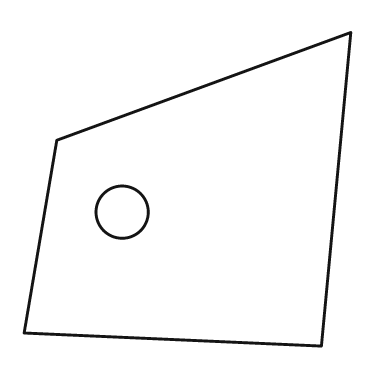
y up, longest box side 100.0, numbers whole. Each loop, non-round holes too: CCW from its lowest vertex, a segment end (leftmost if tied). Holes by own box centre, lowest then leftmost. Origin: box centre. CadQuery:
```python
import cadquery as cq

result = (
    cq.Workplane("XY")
    .moveTo(41.0, -48.0)
    .lineTo(50.0, 48.0)
    .lineTo(-40.0, 15.0)
    .lineTo(-50.0, -44.0)
    .close()
    .moveTo(-20.0, -7.0)
    .circle(8.0)
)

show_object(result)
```